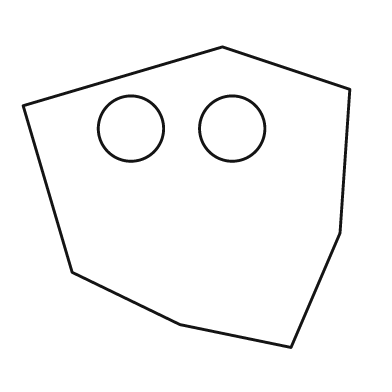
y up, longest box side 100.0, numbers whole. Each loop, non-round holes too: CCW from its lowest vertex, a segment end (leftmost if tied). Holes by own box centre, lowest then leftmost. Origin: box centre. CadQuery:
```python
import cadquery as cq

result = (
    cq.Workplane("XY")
    .moveTo(32.0, -46.0)
    .lineTo(47.0, -11.0)
    .lineTo(50.0, 33.0)
    .lineTo(11.0, 46.0)
    .lineTo(-50.0, 28.0)
    .lineTo(-35.0, -23.0)
    .lineTo(-2.0, -39.0)
    .close()
    .moveTo(-17.0, 21.0)
    .circle(10.0)
    .moveTo(14.0, 21.0)
    .circle(10.0)
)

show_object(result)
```